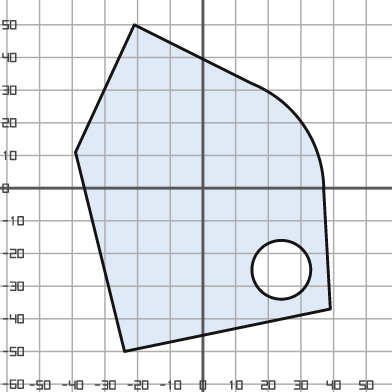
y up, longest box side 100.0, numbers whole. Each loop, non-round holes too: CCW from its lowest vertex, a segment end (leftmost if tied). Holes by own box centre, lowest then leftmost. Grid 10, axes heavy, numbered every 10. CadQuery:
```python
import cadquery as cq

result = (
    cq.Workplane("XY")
    .moveTo(-24.0, -50.0)
    .lineTo(39.0, -37.0)
    .lineTo(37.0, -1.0)
    .threePointArc((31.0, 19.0), (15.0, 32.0))
    .lineTo(-21.0, 50.0)
    .lineTo(-39.0, 11.0)
    .close()
    .moveTo(24.0, -25.0)
    .circle(9.0)
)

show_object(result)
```